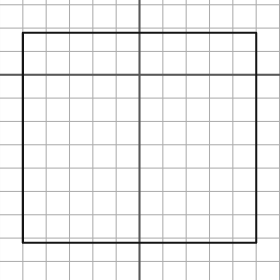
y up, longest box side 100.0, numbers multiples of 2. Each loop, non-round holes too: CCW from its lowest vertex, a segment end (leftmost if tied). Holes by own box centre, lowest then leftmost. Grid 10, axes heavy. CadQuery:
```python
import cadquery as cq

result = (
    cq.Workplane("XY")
    .moveTo(-50.0, -72.0)
    .lineTo(50.0, -72.0)
    .lineTo(50.0, 18.0)
    .lineTo(-50.0, 18.0)
    .close()
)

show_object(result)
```